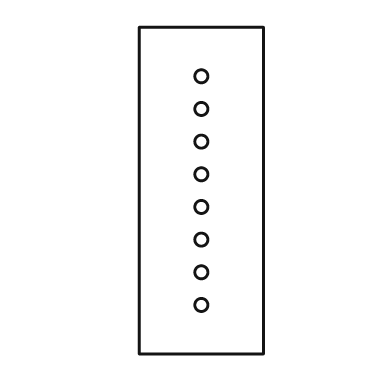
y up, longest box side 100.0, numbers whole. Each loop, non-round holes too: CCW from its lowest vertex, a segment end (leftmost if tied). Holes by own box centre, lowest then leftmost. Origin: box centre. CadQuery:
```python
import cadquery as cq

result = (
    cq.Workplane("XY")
    .moveTo(-19.0, -50.0)
    .lineTo(19.0, -50.0)
    .lineTo(19.0, 50.0)
    .lineTo(-19.0, 50.0)
    .close()
    .moveTo(0.0, -35.0)
    .circle(2.0)
    .moveTo(0.0, -25.0)
    .circle(2.0)
    .moveTo(0.0, -15.0)
    .circle(2.0)
    .moveTo(0.0, -5.0)
    .circle(2.0)
    .moveTo(0.0, 5.0)
    .circle(2.0)
    .moveTo(0.0, 15.0)
    .circle(2.0)
    .moveTo(0.0, 25.0)
    .circle(2.0)
    .moveTo(0.0, 35.0)
    .circle(2.0)
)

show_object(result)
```